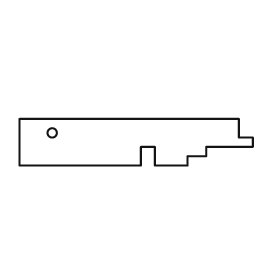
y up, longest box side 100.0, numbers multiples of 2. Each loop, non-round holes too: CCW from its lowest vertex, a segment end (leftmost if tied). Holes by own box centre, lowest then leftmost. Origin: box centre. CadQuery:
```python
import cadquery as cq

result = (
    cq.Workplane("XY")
    .moveTo(-50.0, -10.0)
    .lineTo(2.0, -10.0)
    .lineTo(2.0, -2.0)
    .lineTo(8.0, -2.0)
    .lineTo(8.0, -10.0)
    .lineTo(22.0, -10.0)
    .lineTo(22.0, -6.0)
    .lineTo(30.0, -6.0)
    .lineTo(30.0, -2.0)
    .lineTo(50.0, -2.0)
    .lineTo(50.0, 2.0)
    .lineTo(44.0, 2.0)
    .lineTo(44.0, 10.0)
    .lineTo(-50.0, 10.0)
    .close()
    .moveTo(-36.0, 4.0)
    .circle(2.0)
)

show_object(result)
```